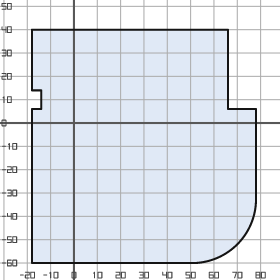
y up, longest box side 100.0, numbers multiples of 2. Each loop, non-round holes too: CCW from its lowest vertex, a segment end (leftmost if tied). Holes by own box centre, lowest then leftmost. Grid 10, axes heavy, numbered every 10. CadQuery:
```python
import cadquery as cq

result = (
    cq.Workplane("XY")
    .moveTo(-18.0, -60.0)
    .lineTo(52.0, -60.0)
    .threePointArc((70.0, -52.0), (78.0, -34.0))
    .lineTo(78.0, 6.0)
    .lineTo(66.0, 6.0)
    .lineTo(66.0, 40.0)
    .lineTo(-18.0, 40.0)
    .lineTo(-18.0, 14.0)
    .lineTo(-14.0, 14.0)
    .lineTo(-14.0, 6.0)
    .lineTo(-18.0, 6.0)
    .close()
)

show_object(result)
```